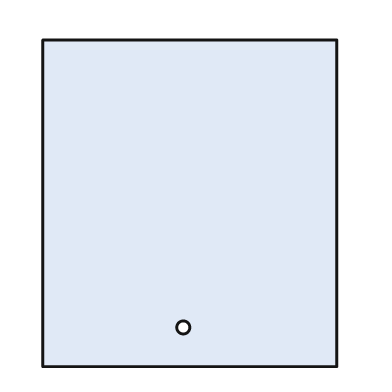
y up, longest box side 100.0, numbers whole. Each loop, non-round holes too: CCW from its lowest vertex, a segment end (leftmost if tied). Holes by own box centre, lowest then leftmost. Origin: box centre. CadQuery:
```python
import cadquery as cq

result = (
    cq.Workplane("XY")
    .moveTo(-45.0, -50.0)
    .lineTo(45.0, -50.0)
    .lineTo(45.0, 50.0)
    .lineTo(-45.0, 50.0)
    .close()
    .moveTo(-2.0, -38.0)
    .circle(2.0)
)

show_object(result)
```